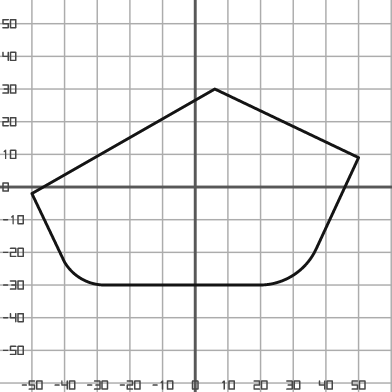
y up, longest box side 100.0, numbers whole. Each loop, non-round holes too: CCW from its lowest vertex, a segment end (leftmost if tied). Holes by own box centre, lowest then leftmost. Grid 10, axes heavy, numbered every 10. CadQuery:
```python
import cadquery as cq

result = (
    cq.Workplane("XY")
    .moveTo(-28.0, -30.0)
    .lineTo(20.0, -30.0)
    .threePointArc((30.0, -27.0), (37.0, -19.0))
    .lineTo(50.0, 9.0)
    .lineTo(6.0, 30.0)
    .lineTo(-50.0, -2.0)
    .lineTo(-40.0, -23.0)
    .threePointArc((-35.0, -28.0), (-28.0, -30.0))
    .close()
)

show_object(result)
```